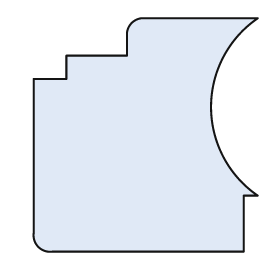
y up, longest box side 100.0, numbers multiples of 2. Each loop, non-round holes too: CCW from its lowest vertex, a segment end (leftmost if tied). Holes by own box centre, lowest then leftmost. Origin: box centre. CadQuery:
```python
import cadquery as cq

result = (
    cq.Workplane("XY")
    .moveTo(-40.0, -50.0)
    .lineTo(42.0, -50.0)
    .lineTo(42.0, -26.0)
    .lineTo(48.0, -26.0)
    .threePointArc((28.0, 12.0), (48.0, 50.0))
    .lineTo(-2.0, 50.0)
    .threePointArc((-6.0, 48.0), (-8.0, 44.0))
    .lineTo(-8.0, 34.0)
    .lineTo(-34.0, 34.0)
    .lineTo(-34.0, 24.0)
    .lineTo(-48.0, 24.0)
    .lineTo(-48.0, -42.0)
    .threePointArc((-46.0, -48.0), (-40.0, -50.0))
    .close()
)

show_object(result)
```